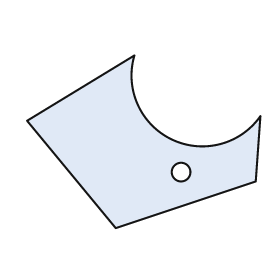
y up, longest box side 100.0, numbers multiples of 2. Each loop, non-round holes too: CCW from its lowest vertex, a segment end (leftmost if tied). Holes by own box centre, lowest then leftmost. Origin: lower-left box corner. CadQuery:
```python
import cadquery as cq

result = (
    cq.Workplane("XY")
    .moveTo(38.0, 0.0)
    .lineTo(98.0, 20.0)
    .lineTo(100.0, 48.0)
    .threePointArc((62.0, 38.0), (46.0, 74.0))
    .lineTo(0.0, 46.0)
    .close()
    .moveTo(66.0, 24.0)
    .circle(4.0)
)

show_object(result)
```